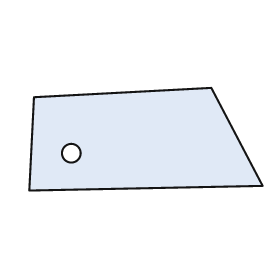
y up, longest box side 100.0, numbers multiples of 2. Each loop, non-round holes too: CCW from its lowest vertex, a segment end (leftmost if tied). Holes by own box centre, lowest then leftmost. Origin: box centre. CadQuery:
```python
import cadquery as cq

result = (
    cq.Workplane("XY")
    .moveTo(-50.0, -22.0)
    .lineTo(50.0, -20.0)
    .lineTo(28.0, 22.0)
    .lineTo(-48.0, 18.0)
    .close()
    .moveTo(-32.0, -6.0)
    .circle(4.0)
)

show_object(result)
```